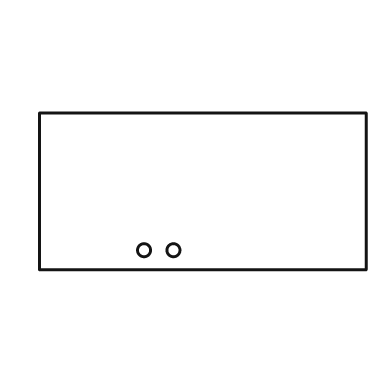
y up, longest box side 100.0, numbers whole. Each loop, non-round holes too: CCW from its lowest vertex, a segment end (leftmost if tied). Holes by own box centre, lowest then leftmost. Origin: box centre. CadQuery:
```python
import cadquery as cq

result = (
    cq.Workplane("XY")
    .moveTo(-50.0, -24.0)
    .lineTo(50.0, -24.0)
    .lineTo(50.0, 24.0)
    .lineTo(-50.0, 24.0)
    .close()
    .moveTo(-18.0, -18.0)
    .circle(2.0)
    .moveTo(-9.0, -18.0)
    .circle(2.0)
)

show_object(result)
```